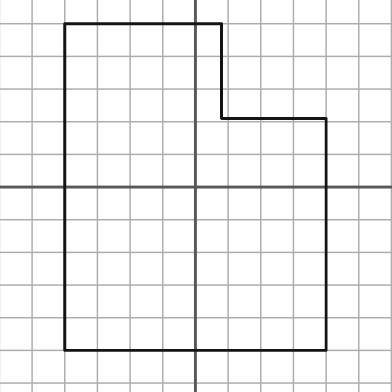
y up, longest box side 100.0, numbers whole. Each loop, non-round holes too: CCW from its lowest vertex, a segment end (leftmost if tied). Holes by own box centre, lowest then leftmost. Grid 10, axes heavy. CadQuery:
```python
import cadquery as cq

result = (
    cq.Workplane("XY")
    .moveTo(-40.0, -50.0)
    .lineTo(40.0, -50.0)
    .lineTo(40.0, 21.0)
    .lineTo(8.0, 21.0)
    .lineTo(8.0, 50.0)
    .lineTo(-40.0, 50.0)
    .close()
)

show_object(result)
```